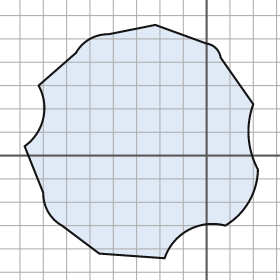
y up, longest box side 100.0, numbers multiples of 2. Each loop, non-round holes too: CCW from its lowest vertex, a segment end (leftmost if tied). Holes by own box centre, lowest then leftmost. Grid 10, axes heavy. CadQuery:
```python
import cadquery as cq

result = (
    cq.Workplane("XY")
    .moveTo(-18.0, -44.0)
    .threePointArc((-8.0, -32.0), (8.0, -30.0))
    .threePointArc((18.0, -20.0), (22.0, -6.0))
    .threePointArc((18.0, 8.0), (20.0, 22.0))
    .lineTo(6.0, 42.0)
    .threePointArc((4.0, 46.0), (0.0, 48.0))
    .lineTo(-22.0, 56.0)
    .lineTo(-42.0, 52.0)
    .threePointArc((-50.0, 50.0), (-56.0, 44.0))
    .lineTo(-72.0, 30.0)
    .threePointArc((-70.0, 16.0), (-78.0, 4.0))
    .lineTo(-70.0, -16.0)
    .threePointArc((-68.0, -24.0), (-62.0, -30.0))
    .lineTo(-46.0, -42.0)
    .close()
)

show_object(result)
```